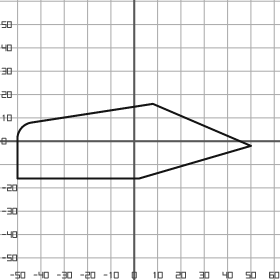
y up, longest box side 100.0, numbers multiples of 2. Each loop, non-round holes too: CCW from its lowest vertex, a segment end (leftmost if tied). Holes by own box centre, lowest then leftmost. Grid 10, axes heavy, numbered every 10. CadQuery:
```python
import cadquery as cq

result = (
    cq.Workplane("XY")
    .moveTo(-50.0, -16.0)
    .lineTo(2.0, -16.0)
    .lineTo(50.0, -2.0)
    .lineTo(8.0, 16.0)
    .lineTo(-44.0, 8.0)
    .threePointArc((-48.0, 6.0), (-50.0, 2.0))
    .close()
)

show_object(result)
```